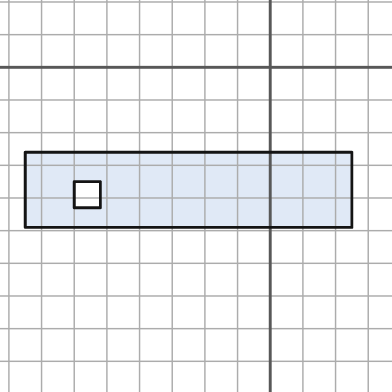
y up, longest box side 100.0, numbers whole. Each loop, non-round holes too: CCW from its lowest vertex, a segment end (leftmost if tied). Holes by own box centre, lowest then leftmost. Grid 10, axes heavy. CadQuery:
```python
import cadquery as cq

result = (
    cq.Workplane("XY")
    .moveTo(-75.0, -49.0)
    .lineTo(25.0, -49.0)
    .lineTo(25.0, -26.0)
    .lineTo(-75.0, -26.0)
    .close()
    .moveTo(-60.0, -43.0)
    .lineTo(-52.0, -43.0)
    .lineTo(-52.0, -35.0)
    .lineTo(-60.0, -35.0)
    .close()
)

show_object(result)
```